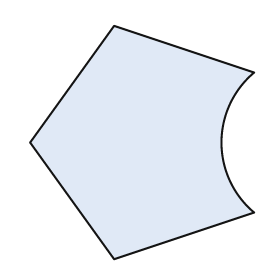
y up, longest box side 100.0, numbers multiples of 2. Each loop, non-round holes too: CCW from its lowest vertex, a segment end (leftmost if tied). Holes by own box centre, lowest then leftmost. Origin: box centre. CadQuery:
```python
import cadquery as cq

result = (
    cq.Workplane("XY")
    .moveTo(-12.0, -50.0)
    .lineTo(48.0, -30.0)
    .threePointArc((34.0, 0.0), (48.0, 30.0))
    .lineTo(-12.0, 50.0)
    .lineTo(-48.0, 0.0)
    .close()
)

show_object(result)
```